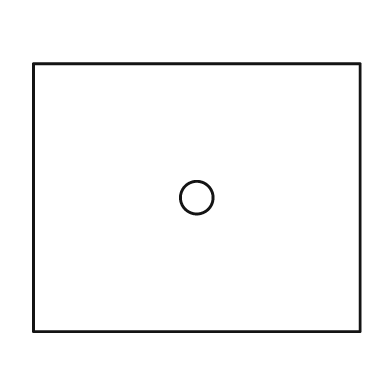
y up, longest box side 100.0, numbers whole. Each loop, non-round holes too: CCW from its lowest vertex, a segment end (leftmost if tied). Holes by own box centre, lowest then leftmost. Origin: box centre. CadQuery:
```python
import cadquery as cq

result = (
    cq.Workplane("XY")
    .moveTo(-50.0, -41.0)
    .lineTo(50.0, -41.0)
    .lineTo(50.0, 41.0)
    .lineTo(-50.0, 41.0)
    .close()
    .moveTo(0.0, 0.0)
    .circle(5.0)
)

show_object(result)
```